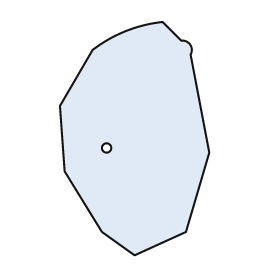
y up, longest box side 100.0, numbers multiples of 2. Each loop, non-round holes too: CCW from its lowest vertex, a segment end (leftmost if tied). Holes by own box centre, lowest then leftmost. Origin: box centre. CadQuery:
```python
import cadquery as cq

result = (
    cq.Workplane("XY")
    .moveTo(0.0, -50.0)
    .lineTo(22.0, -40.0)
    .lineTo(32.0, -6.0)
    .lineTo(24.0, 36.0)
    .threePointArc((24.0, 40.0), (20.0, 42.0))
    .lineTo(12.0, 50.0)
    .threePointArc((-4.0, 46.0), (-18.0, 38.0))
    .lineTo(-32.0, 14.0)
    .lineTo(-30.0, -14.0)
    .lineTo(-14.0, -40.0)
    .close()
    .moveTo(-12.0, -4.0)
    .circle(2.0)
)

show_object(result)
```